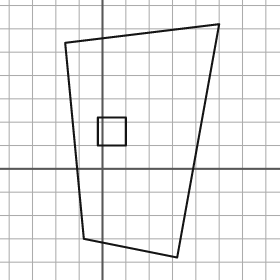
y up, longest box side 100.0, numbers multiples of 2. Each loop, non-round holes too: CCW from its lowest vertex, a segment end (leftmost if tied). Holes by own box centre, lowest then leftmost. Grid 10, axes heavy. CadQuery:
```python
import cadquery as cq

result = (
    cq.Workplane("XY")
    .moveTo(32.0, -38.0)
    .lineTo(50.0, 62.0)
    .lineTo(-16.0, 54.0)
    .lineTo(-8.0, -30.0)
    .close()
    .moveTo(-2.0, 10.0)
    .lineTo(10.0, 10.0)
    .lineTo(10.0, 22.0)
    .lineTo(-2.0, 22.0)
    .close()
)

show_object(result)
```